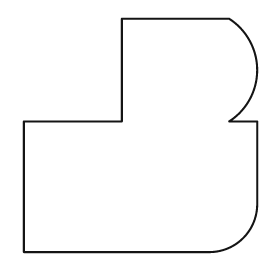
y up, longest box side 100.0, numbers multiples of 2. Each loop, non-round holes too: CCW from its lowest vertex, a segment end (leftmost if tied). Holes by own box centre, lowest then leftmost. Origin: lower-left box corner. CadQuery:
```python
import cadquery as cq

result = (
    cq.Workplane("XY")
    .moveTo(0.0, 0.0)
    .lineTo(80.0, 0.0)
    .threePointArc((94.0, 6.0), (100.0, 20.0))
    .lineTo(100.0, 56.0)
    .lineTo(88.0, 56.0)
    .threePointArc((100.0, 78.0), (88.0, 100.0))
    .lineTo(42.0, 100.0)
    .lineTo(42.0, 56.0)
    .lineTo(0.0, 56.0)
    .close()
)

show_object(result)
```